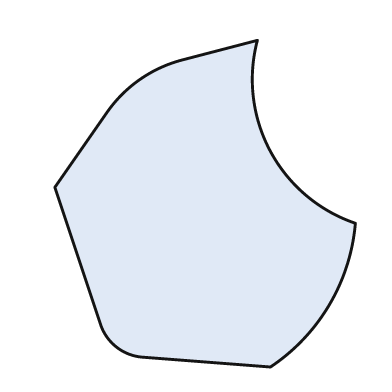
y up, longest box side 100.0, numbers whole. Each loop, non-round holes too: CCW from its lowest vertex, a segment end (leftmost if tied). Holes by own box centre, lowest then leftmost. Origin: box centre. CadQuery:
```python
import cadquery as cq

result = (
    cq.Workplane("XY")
    .moveTo(20.0, -50.0)
    .threePointArc((38.0, -31.0), (46.0, -6.0))
    .threePointArc((20.0, 16.0), (16.0, 50.0))
    .lineTo(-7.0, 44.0)
    .threePointArc((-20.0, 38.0), (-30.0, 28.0))
    .lineTo(-46.0, 5.0)
    .lineTo(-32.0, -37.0)
    .threePointArc((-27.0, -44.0), (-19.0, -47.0))
    .close()
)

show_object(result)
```